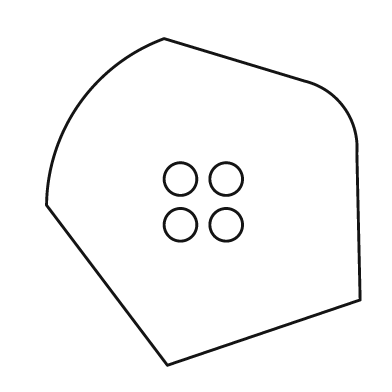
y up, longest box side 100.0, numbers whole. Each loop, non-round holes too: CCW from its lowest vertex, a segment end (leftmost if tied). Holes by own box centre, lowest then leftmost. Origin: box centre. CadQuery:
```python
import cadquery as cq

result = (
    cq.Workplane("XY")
    .moveTo(-11.0, -50.0)
    .lineTo(48.0, -30.0)
    .lineTo(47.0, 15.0)
    .threePointArc((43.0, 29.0), (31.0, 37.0))
    .lineTo(-12.0, 50.0)
    .threePointArc((-38.0, 30.0), (-48.0, -1.0))
    .close()
    .moveTo(-7.0, -7.0)
    .circle(5.0)
    .moveTo(7.0, -7.0)
    .circle(5.0)
    .moveTo(-7.0, 7.0)
    .circle(5.0)
    .moveTo(7.0, 7.0)
    .circle(5.0)
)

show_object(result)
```